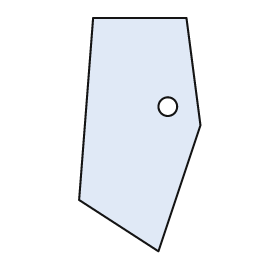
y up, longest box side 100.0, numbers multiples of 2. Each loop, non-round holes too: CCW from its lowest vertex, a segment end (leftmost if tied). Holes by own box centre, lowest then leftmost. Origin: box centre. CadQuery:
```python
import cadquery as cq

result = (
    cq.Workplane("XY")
    .moveTo(8.0, -50.0)
    .lineTo(26.0, 4.0)
    .lineTo(20.0, 50.0)
    .lineTo(-20.0, 50.0)
    .lineTo(-26.0, -28.0)
    .close()
    .moveTo(12.0, 12.0)
    .circle(4.0)
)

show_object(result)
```